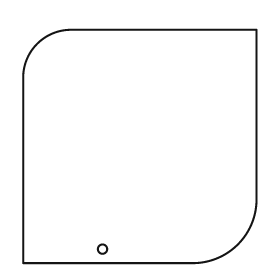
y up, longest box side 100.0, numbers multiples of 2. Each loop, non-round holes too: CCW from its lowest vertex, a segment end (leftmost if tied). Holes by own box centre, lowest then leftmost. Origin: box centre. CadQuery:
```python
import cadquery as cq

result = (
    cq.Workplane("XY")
    .moveTo(-50.0, -50.0)
    .lineTo(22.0, -50.0)
    .threePointArc((42.0, -42.0), (50.0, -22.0))
    .lineTo(50.0, 50.0)
    .lineTo(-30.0, 50.0)
    .threePointArc((-44.0, 44.0), (-50.0, 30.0))
    .close()
    .moveTo(-16.0, -44.0)
    .circle(2.0)
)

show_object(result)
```